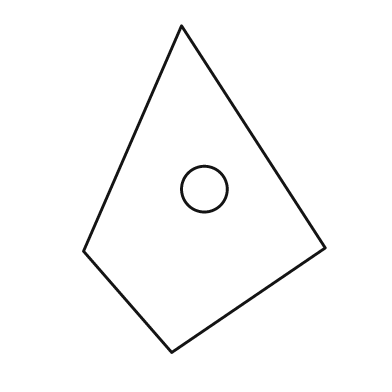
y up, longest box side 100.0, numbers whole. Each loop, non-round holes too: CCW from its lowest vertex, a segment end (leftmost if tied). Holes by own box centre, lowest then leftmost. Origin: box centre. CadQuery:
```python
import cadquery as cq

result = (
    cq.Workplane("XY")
    .moveTo(-10.0, -50.0)
    .lineTo(37.0, -18.0)
    .lineTo(-7.0, 50.0)
    .lineTo(-37.0, -19.0)
    .close()
    .moveTo(0.0, 0.0)
    .circle(7.0)
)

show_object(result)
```